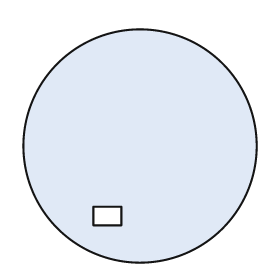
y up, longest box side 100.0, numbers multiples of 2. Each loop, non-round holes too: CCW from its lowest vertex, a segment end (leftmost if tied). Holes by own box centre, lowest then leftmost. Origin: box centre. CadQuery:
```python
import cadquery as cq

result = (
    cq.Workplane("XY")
    .moveTo(0.0, 0.0)
    .circle(50.0)
    .moveTo(-20.0, -34.0)
    .lineTo(-8.0, -34.0)
    .lineTo(-8.0, -26.0)
    .lineTo(-20.0, -26.0)
    .close()
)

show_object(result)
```